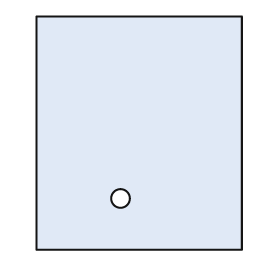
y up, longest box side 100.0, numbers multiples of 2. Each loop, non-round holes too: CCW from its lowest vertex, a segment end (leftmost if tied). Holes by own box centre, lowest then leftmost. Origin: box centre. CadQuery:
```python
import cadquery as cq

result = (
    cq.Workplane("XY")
    .moveTo(-44.0, -50.0)
    .lineTo(44.0, -50.0)
    .lineTo(44.0, 50.0)
    .lineTo(-44.0, 50.0)
    .close()
    .moveTo(-8.0, -28.0)
    .circle(4.0)
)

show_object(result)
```